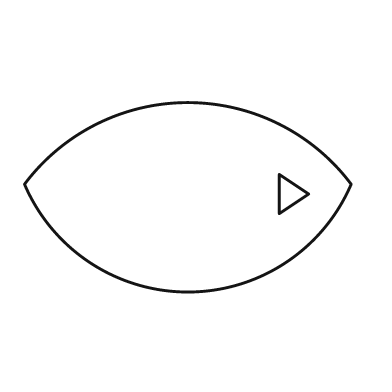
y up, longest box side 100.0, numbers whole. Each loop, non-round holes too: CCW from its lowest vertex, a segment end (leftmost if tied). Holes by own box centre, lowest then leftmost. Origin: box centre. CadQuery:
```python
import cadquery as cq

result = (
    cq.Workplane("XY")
    .moveTo(-50.0, 4.0)
    .threePointArc((0.0, -29.0), (50.0, 4.0))
    .threePointArc((0.0, 29.0), (-50.0, 4.0))
    .close()
    .moveTo(28.0, -5.0)
    .lineTo(37.0, 1.0)
    .lineTo(28.0, 7.0)
    .close()
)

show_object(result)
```